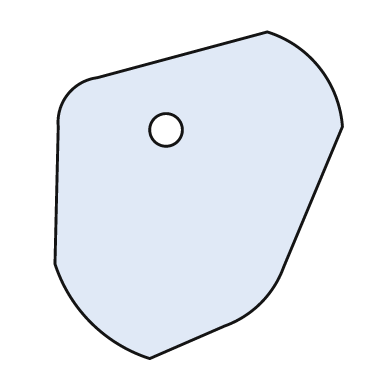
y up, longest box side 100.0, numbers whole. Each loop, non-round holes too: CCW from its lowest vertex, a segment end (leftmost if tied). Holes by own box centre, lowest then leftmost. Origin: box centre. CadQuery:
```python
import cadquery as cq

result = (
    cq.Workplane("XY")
    .moveTo(-15.0, -50.0)
    .lineTo(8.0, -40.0)
    .threePointArc((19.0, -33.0), (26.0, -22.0))
    .lineTo(44.0, 21.0)
    .threePointArc((37.0, 39.0), (21.0, 50.0))
    .lineTo(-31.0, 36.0)
    .threePointArc((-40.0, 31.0), (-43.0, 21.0))
    .lineTo(-44.0, -21.0)
    .threePointArc((-33.0, -39.0), (-15.0, -50.0))
    .close()
    .moveTo(-10.0, 20.0)
    .circle(5.0)
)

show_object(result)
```